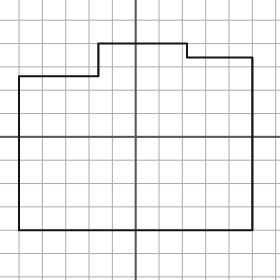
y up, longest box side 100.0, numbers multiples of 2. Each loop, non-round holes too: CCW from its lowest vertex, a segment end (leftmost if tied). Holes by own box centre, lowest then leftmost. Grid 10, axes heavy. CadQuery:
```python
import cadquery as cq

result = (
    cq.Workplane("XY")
    .moveTo(-50.0, -40.0)
    .lineTo(50.0, -40.0)
    .lineTo(50.0, 34.0)
    .lineTo(22.0, 34.0)
    .lineTo(22.0, 40.0)
    .lineTo(-16.0, 40.0)
    .lineTo(-16.0, 26.0)
    .lineTo(-50.0, 26.0)
    .close()
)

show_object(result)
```